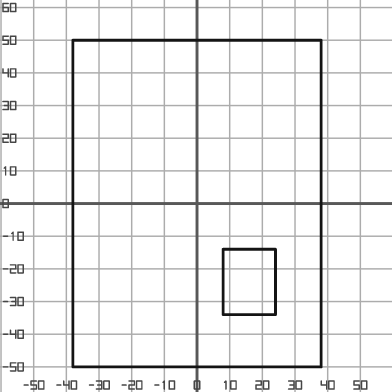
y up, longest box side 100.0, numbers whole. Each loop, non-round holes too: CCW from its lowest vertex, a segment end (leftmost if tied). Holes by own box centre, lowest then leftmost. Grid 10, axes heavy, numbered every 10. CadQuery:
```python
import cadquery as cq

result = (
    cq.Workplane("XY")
    .moveTo(-38.0, -50.0)
    .lineTo(38.0, -50.0)
    .lineTo(38.0, 50.0)
    .lineTo(-38.0, 50.0)
    .close()
    .moveTo(8.0, -34.0)
    .lineTo(24.0, -34.0)
    .lineTo(24.0, -14.0)
    .lineTo(8.0, -14.0)
    .close()
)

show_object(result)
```